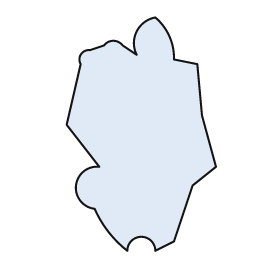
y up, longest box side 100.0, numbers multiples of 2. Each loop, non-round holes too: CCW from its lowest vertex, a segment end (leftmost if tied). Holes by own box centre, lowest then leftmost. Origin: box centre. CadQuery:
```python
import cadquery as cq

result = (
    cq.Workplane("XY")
    .moveTo(-6.0, -50.0)
    .threePointArc((0.0, -44.0), (6.0, -50.0))
    .lineTo(14.0, -46.0)
    .lineTo(22.0, -22.0)
    .lineTo(32.0, -14.0)
    .lineTo(26.0, 8.0)
    .lineTo(24.0, 30.0)
    .lineTo(14.0, 32.0)
    .threePointArc((12.0, 42.0), (6.0, 50.0))
    .threePointArc((-2.0, 44.0), (-2.0, 34.0))
    .lineTo(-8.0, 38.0)
    .threePointArc((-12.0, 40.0), (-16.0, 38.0))
    .lineTo(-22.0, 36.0)
    .threePointArc((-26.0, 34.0), (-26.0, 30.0))
    .lineTo(-32.0, 4.0)
    .lineTo(-18.0, -14.0)
    .threePointArc((-28.0, -22.0), (-20.0, -32.0))
    .threePointArc((-14.0, -42.0), (-6.0, -50.0))
    .close()
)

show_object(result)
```